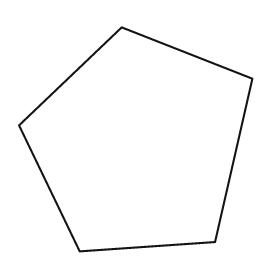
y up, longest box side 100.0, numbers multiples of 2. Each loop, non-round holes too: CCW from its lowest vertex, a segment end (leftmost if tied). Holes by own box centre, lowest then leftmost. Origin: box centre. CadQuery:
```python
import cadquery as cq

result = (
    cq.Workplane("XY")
    .moveTo(-24.0, -48.0)
    .lineTo(34.0, -44.0)
    .lineTo(50.0, 26.0)
    .lineTo(-6.0, 48.0)
    .lineTo(-50.0, 6.0)
    .close()
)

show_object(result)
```